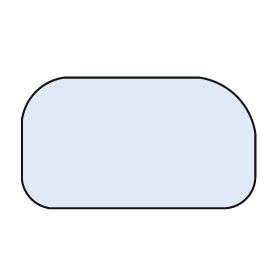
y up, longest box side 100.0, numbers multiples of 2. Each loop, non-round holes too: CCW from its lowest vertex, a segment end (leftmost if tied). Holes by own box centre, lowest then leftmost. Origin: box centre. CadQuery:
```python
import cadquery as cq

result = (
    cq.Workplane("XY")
    .moveTo(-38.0, -28.0)
    .lineTo(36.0, -28.0)
    .threePointArc((46.0, -24.0), (50.0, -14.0))
    .lineTo(50.0, 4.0)
    .threePointArc((42.0, 20.0), (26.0, 28.0))
    .lineTo(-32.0, 28.0)
    .threePointArc((-44.0, 22.0), (-50.0, 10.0))
    .lineTo(-50.0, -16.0)
    .threePointArc((-46.0, -24.0), (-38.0, -28.0))
    .close()
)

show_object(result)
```